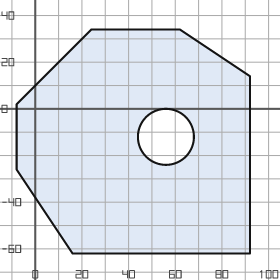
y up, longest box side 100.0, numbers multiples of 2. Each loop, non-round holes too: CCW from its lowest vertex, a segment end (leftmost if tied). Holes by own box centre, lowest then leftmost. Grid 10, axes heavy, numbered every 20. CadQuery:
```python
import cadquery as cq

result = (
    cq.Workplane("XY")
    .moveTo(16.0, -62.0)
    .lineTo(92.0, -62.0)
    .lineTo(92.0, 14.0)
    .lineTo(62.0, 34.0)
    .lineTo(24.0, 34.0)
    .lineTo(-8.0, 2.0)
    .lineTo(-8.0, -26.0)
    .close()
    .moveTo(56.0, -12.0)
    .circle(12.0)
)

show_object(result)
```